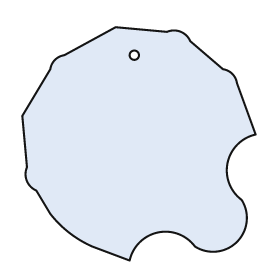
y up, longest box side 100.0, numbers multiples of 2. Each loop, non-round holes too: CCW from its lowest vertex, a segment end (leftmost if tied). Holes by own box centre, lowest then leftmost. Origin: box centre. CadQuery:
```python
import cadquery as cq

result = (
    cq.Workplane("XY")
    .moveTo(-4.0, -50.0)
    .threePointArc((8.0, -38.0), (24.0, -44.0))
    .threePointArc((42.0, -42.0), (44.0, -24.0))
    .threePointArc((38.0, -8.0), (50.0, 4.0))
    .lineTo(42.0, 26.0)
    .threePointArc((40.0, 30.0), (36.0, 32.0))
    .lineTo(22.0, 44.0)
    .threePointArc((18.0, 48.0), (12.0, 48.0))
    .lineTo(-10.0, 50.0)
    .lineTo(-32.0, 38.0)
    .threePointArc((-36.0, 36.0), (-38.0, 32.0))
    .lineTo(-50.0, 12.0)
    .lineTo(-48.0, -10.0)
    .threePointArc((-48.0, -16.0), (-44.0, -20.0))
    .lineTo(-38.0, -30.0)
    .threePointArc((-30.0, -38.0), (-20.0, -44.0))
    .close()
    .moveTo(-2.0, 38.0)
    .circle(2.0)
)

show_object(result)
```